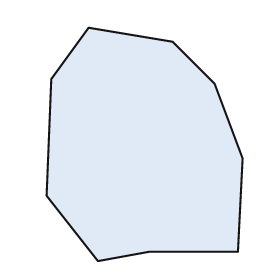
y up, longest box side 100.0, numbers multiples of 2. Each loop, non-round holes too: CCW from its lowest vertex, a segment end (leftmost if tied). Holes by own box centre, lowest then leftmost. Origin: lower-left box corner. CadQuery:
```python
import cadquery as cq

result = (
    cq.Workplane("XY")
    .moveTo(22.0, 0.0)
    .lineTo(44.0, 4.0)
    .lineTo(82.0, 4.0)
    .lineTo(84.0, 44.0)
    .lineTo(72.0, 76.0)
    .lineTo(54.0, 94.0)
    .lineTo(18.0, 100.0)
    .lineTo(2.0, 78.0)
    .lineTo(0.0, 28.0)
    .close()
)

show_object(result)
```